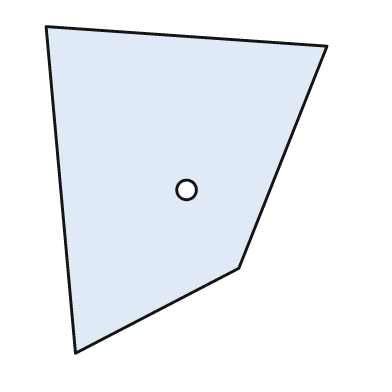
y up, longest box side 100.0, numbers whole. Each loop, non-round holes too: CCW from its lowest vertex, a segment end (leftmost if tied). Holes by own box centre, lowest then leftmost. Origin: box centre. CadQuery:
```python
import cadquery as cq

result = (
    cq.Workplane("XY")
    .moveTo(-34.0, -50.0)
    .lineTo(16.0, -24.0)
    .lineTo(43.0, 44.0)
    .lineTo(-43.0, 50.0)
    .close()
    .moveTo(0.0, 0.0)
    .circle(3.0)
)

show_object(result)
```